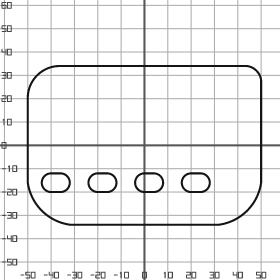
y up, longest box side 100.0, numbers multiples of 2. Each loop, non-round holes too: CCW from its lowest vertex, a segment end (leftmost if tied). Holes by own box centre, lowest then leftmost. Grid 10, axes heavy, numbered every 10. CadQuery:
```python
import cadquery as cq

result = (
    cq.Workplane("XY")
    .moveTo(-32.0, -34.0)
    .lineTo(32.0, -34.0)
    .threePointArc((44.0, -28.0), (50.0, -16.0))
    .lineTo(50.0, 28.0)
    .threePointArc((48.0, 32.0), (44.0, 34.0))
    .lineTo(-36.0, 34.0)
    .threePointArc((-46.0, 30.0), (-50.0, 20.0))
    .lineTo(-50.0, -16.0)
    .threePointArc((-44.0, -28.0), (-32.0, -34.0))
    .close()
    .moveTo(-40.0, -20.0)
    .lineTo(-36.0, -20.0)
    .threePointArc((-32.0, -16.0), (-36.0, -12.0))
    .lineTo(-40.0, -12.0)
    .threePointArc((-44.0, -16.0), (-40.0, -20.0))
    .close()
    .moveTo(-20.0, -20.0)
    .lineTo(-16.0, -20.0)
    .threePointArc((-12.0, -16.0), (-16.0, -12.0))
    .lineTo(-20.0, -12.0)
    .threePointArc((-24.0, -16.0), (-20.0, -20.0))
    .close()
    .moveTo(0.0, -20.0)
    .lineTo(4.0, -20.0)
    .threePointArc((8.0, -16.0), (4.0, -12.0))
    .lineTo(0.0, -12.0)
    .threePointArc((-4.0, -16.0), (0.0, -20.0))
    .close()
    .moveTo(20.0, -20.0)
    .lineTo(24.0, -20.0)
    .threePointArc((28.0, -16.0), (24.0, -12.0))
    .lineTo(20.0, -12.0)
    .threePointArc((16.0, -16.0), (20.0, -20.0))
    .close()
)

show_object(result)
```